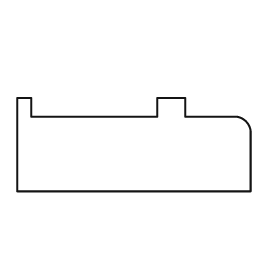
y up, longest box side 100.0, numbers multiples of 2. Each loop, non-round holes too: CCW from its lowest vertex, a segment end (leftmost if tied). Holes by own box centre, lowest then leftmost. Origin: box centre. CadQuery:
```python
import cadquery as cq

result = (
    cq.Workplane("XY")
    .moveTo(-50.0, -20.0)
    .lineTo(50.0, -20.0)
    .lineTo(50.0, 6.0)
    .threePointArc((48.0, 10.0), (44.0, 12.0))
    .lineTo(22.0, 12.0)
    .lineTo(22.0, 20.0)
    .lineTo(10.0, 20.0)
    .lineTo(10.0, 12.0)
    .lineTo(-44.0, 12.0)
    .lineTo(-44.0, 20.0)
    .lineTo(-50.0, 20.0)
    .close()
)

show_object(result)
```